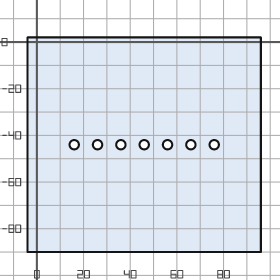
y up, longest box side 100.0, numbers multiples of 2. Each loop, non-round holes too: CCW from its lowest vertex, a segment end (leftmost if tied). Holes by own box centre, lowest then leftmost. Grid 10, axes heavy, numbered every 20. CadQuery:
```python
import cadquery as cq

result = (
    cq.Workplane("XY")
    .moveTo(-4.0, -90.0)
    .lineTo(96.0, -90.0)
    .lineTo(96.0, 2.0)
    .lineTo(-4.0, 2.0)
    .close()
    .moveTo(16.0, -44.0)
    .circle(2.0)
    .moveTo(26.0, -44.0)
    .circle(2.0)
    .moveTo(36.0, -44.0)
    .circle(2.0)
    .moveTo(46.0, -44.0)
    .circle(2.0)
    .moveTo(56.0, -44.0)
    .circle(2.0)
    .moveTo(66.0, -44.0)
    .circle(2.0)
    .moveTo(76.0, -44.0)
    .circle(2.0)
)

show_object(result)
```